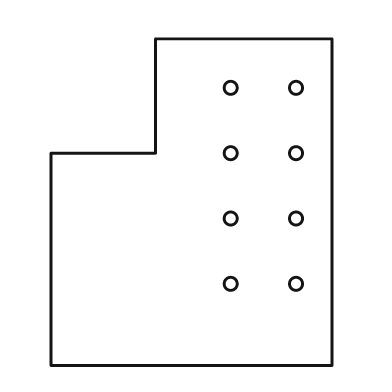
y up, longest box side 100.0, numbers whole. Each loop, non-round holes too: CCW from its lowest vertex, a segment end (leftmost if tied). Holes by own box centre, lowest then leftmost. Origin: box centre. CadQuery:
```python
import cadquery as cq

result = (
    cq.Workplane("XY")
    .moveTo(-43.0, -50.0)
    .lineTo(43.0, -50.0)
    .lineTo(43.0, 50.0)
    .lineTo(-11.0, 50.0)
    .lineTo(-11.0, 15.0)
    .lineTo(-43.0, 15.0)
    .close()
    .moveTo(12.0, -25.0)
    .circle(2.0)
    .moveTo(32.0, -25.0)
    .circle(2.0)
    .moveTo(12.0, -5.0)
    .circle(2.0)
    .moveTo(32.0, -5.0)
    .circle(2.0)
    .moveTo(12.0, 15.0)
    .circle(2.0)
    .moveTo(32.0, 15.0)
    .circle(2.0)
    .moveTo(12.0, 35.0)
    .circle(2.0)
    .moveTo(32.0, 35.0)
    .circle(2.0)
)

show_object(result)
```